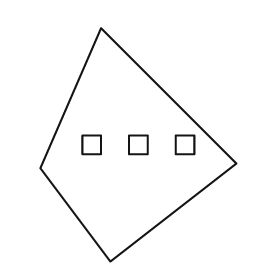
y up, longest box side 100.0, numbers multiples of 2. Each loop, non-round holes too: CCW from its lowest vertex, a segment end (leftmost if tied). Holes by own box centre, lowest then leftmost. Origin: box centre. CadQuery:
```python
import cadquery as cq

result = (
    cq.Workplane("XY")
    .moveTo(-12.0, -50.0)
    .lineTo(42.0, -8.0)
    .lineTo(-16.0, 50.0)
    .lineTo(-42.0, -10.0)
    .close()
    .moveTo(-24.0, -4.0)
    .lineTo(-16.0, -4.0)
    .lineTo(-16.0, 4.0)
    .lineTo(-24.0, 4.0)
    .close()
    .moveTo(-4.0, -4.0)
    .lineTo(4.0, -4.0)
    .lineTo(4.0, 4.0)
    .lineTo(-4.0, 4.0)
    .close()
    .moveTo(16.0, -4.0)
    .lineTo(24.0, -4.0)
    .lineTo(24.0, 4.0)
    .lineTo(16.0, 4.0)
    .close()
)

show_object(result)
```